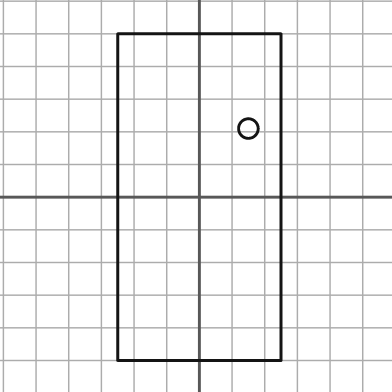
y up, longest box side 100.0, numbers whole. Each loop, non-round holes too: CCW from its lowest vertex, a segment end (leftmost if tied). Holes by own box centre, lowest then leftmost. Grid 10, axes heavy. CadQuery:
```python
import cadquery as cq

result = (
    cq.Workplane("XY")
    .moveTo(-25.0, -50.0)
    .lineTo(25.0, -50.0)
    .lineTo(25.0, 50.0)
    .lineTo(-25.0, 50.0)
    .close()
    .moveTo(15.0, 21.0)
    .circle(3.0)
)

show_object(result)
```